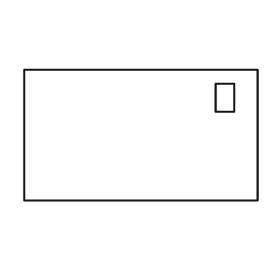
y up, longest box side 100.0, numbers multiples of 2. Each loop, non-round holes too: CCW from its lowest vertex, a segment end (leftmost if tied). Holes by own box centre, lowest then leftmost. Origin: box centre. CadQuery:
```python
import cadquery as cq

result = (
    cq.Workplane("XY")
    .moveTo(-50.0, -28.0)
    .lineTo(50.0, -28.0)
    .lineTo(50.0, 28.0)
    .lineTo(-50.0, 28.0)
    .close()
    .moveTo(32.0, 10.0)
    .lineTo(40.0, 10.0)
    .lineTo(40.0, 22.0)
    .lineTo(32.0, 22.0)
    .close()
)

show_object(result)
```